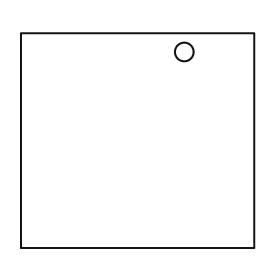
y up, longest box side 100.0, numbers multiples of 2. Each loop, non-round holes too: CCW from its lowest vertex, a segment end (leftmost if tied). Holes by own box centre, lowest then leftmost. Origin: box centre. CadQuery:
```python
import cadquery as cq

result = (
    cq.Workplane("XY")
    .moveTo(-50.0, -46.0)
    .lineTo(50.0, -46.0)
    .lineTo(50.0, 46.0)
    .lineTo(-50.0, 46.0)
    .close()
    .moveTo(20.0, 38.0)
    .circle(4.0)
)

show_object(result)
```